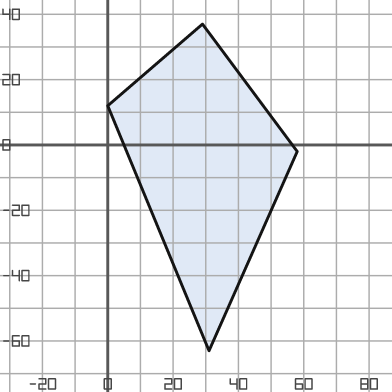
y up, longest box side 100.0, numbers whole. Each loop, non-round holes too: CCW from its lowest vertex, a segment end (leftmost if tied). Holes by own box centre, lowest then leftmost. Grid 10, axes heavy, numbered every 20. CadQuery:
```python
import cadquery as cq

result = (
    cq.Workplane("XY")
    .moveTo(31.0, -63.0)
    .lineTo(58.0, -2.0)
    .lineTo(29.0, 37.0)
    .lineTo(0.0, 12.0)
    .close()
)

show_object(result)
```